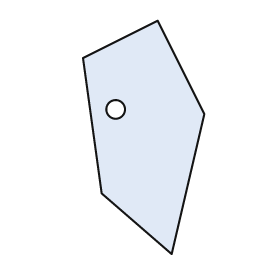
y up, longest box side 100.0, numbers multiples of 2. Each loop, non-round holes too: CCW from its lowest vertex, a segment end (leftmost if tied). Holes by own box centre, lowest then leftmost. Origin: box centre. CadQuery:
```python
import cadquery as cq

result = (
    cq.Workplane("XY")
    .moveTo(12.0, -50.0)
    .lineTo(26.0, 10.0)
    .lineTo(6.0, 50.0)
    .lineTo(-26.0, 34.0)
    .lineTo(-18.0, -24.0)
    .close()
    .moveTo(-12.0, 12.0)
    .circle(4.0)
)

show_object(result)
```